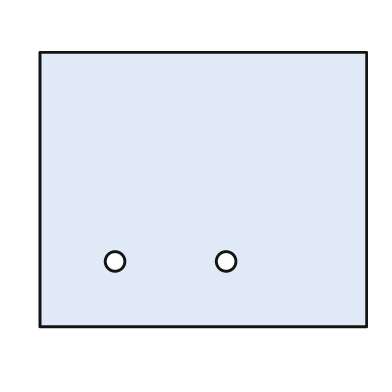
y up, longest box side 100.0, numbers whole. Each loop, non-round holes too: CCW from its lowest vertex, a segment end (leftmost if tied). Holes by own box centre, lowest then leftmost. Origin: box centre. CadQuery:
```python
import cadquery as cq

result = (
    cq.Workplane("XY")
    .moveTo(-50.0, -42.0)
    .lineTo(50.0, -42.0)
    .lineTo(50.0, 42.0)
    .lineTo(-50.0, 42.0)
    .close()
    .moveTo(-27.0, -22.0)
    .circle(3.0)
    .moveTo(7.0, -22.0)
    .circle(3.0)
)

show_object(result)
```